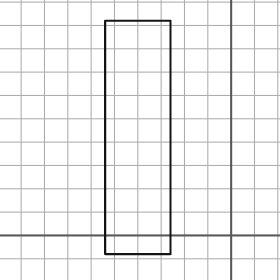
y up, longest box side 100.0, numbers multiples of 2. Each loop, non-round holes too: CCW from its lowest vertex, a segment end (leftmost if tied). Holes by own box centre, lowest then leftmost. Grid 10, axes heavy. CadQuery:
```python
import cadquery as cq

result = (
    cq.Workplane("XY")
    .moveTo(-54.0, -8.0)
    .lineTo(-26.0, -8.0)
    .lineTo(-26.0, 92.0)
    .lineTo(-54.0, 92.0)
    .close()
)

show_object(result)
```